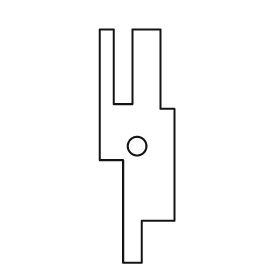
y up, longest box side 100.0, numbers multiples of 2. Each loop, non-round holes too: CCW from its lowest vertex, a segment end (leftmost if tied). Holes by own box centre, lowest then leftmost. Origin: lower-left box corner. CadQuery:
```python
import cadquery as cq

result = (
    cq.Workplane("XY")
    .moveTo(10.0, 0.0)
    .lineTo(18.0, 0.0)
    .lineTo(18.0, 18.0)
    .lineTo(32.0, 18.0)
    .lineTo(32.0, 66.0)
    .lineTo(26.0, 66.0)
    .lineTo(26.0, 100.0)
    .lineTo(14.0, 100.0)
    .lineTo(14.0, 68.0)
    .lineTo(6.0, 68.0)
    .lineTo(6.0, 100.0)
    .lineTo(0.0, 100.0)
    .lineTo(0.0, 44.0)
    .lineTo(10.0, 44.0)
    .close()
    .moveTo(16.0, 50.0)
    .circle(4.0)
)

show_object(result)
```